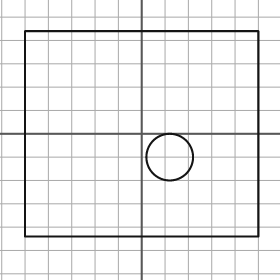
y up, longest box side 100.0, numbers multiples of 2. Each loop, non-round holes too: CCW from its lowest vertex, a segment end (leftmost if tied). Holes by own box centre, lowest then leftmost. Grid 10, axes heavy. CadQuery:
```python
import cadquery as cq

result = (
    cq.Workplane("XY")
    .moveTo(-50.0, -44.0)
    .lineTo(50.0, -44.0)
    .lineTo(50.0, 44.0)
    .lineTo(-50.0, 44.0)
    .close()
    .moveTo(12.0, -10.0)
    .circle(10.0)
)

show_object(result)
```